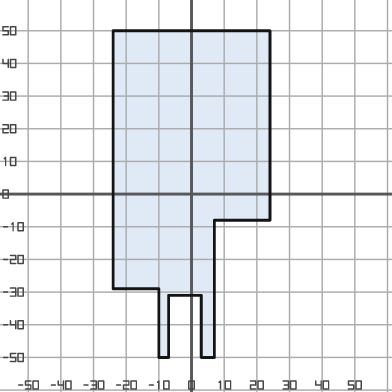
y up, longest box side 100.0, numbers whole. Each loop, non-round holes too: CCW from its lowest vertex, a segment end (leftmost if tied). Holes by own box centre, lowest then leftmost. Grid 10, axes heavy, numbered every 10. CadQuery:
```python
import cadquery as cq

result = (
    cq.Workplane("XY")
    .moveTo(-10.0, -50.0)
    .lineTo(-7.0, -50.0)
    .lineTo(-7.0, -31.0)
    .lineTo(3.0, -31.0)
    .lineTo(3.0, -50.0)
    .lineTo(7.0, -50.0)
    .lineTo(7.0, -8.0)
    .lineTo(24.0, -8.0)
    .lineTo(24.0, 50.0)
    .lineTo(-24.0, 50.0)
    .lineTo(-24.0, -29.0)
    .lineTo(-10.0, -29.0)
    .close()
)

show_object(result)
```